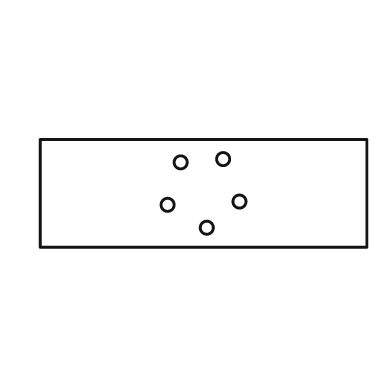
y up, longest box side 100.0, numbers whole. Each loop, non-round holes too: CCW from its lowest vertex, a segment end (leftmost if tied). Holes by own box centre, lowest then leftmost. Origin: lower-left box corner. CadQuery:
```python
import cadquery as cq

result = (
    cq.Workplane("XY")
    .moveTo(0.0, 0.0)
    .lineTo(100.0, 0.0)
    .lineTo(100.0, 33.0)
    .lineTo(0.0, 33.0)
    .close()
    .moveTo(51.0, 6.0)
    .circle(2.0)
    .moveTo(39.0, 13.0)
    .circle(2.0)
    .moveTo(61.0, 14.0)
    .circle(2.0)
    .moveTo(43.0, 26.0)
    .circle(2.0)
    .moveTo(56.0, 27.0)
    .circle(2.0)
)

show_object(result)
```